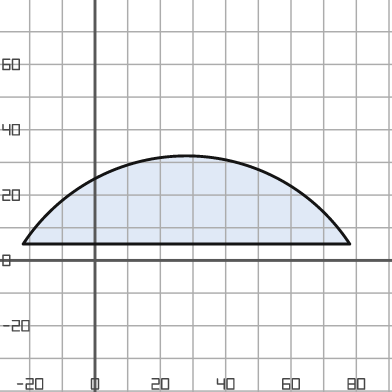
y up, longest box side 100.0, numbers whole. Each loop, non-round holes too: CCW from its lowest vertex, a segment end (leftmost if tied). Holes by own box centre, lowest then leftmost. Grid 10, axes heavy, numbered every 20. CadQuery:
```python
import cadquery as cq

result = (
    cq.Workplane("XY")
    .moveTo(-22.0, 5.0)
    .lineTo(78.0, 5.0)
    .threePointArc((28.0, 32.0), (-22.0, 5.0))
    .close()
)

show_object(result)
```